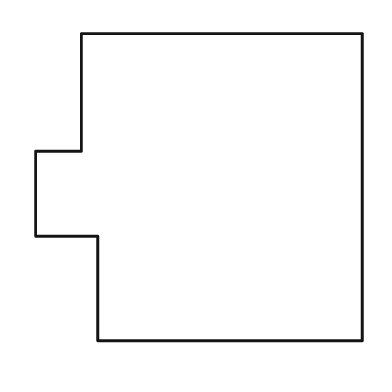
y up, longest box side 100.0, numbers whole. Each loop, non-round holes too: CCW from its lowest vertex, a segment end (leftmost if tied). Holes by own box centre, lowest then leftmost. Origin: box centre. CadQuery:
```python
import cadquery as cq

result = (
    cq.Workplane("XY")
    .moveTo(-31.0, -47.0)
    .lineTo(50.0, -47.0)
    .lineTo(50.0, 47.0)
    .lineTo(-36.0, 47.0)
    .lineTo(-36.0, 11.0)
    .lineTo(-50.0, 11.0)
    .lineTo(-50.0, -15.0)
    .lineTo(-31.0, -15.0)
    .close()
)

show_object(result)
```